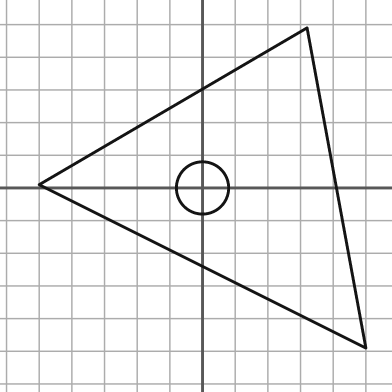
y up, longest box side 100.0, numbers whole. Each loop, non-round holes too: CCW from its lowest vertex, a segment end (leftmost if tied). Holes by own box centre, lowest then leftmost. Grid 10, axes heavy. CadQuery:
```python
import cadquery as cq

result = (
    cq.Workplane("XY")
    .moveTo(50.0, -49.0)
    .lineTo(32.0, 49.0)
    .lineTo(-50.0, 1.0)
    .close()
    .moveTo(0.0, 0.0)
    .circle(8.0)
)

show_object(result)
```